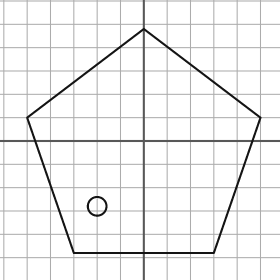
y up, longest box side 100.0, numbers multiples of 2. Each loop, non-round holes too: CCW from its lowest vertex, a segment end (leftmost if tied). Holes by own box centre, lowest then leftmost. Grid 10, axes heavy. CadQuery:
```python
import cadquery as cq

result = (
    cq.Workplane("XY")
    .moveTo(-30.0, -48.0)
    .lineTo(30.0, -48.0)
    .lineTo(50.0, 10.0)
    .lineTo(0.0, 48.0)
    .lineTo(-50.0, 10.0)
    .close()
    .moveTo(-20.0, -28.0)
    .circle(4.0)
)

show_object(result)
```